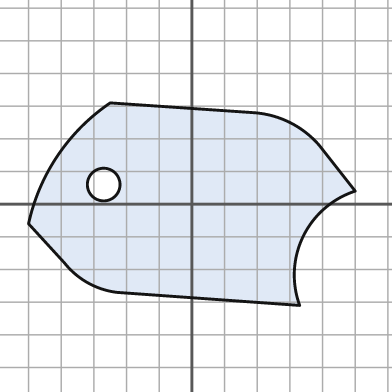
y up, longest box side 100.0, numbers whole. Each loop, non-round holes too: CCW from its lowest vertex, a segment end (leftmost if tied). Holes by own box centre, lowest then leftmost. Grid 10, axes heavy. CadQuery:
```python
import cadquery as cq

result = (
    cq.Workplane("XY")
    .moveTo(33.0, -31.0)
    .threePointArc((34.0, -10.0), (50.0, 4.0))
    .lineTo(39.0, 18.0)
    .threePointArc((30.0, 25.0), (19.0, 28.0))
    .lineTo(-25.0, 31.0)
    .threePointArc((-41.0, 15.0), (-50.0, -6.0))
    .lineTo(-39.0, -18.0)
    .threePointArc((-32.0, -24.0), (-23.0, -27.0))
    .close()
    .moveTo(-27.0, 6.0)
    .circle(5.0)
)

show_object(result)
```